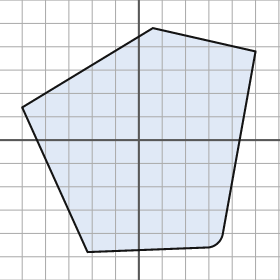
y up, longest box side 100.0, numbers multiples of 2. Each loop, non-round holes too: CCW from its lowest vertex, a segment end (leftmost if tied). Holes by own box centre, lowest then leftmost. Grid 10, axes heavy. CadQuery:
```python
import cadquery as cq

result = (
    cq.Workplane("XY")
    .moveTo(-22.0, -48.0)
    .lineTo(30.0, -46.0)
    .threePointArc((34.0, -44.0), (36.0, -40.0))
    .lineTo(50.0, 38.0)
    .lineTo(6.0, 48.0)
    .lineTo(-50.0, 14.0)
    .close()
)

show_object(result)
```